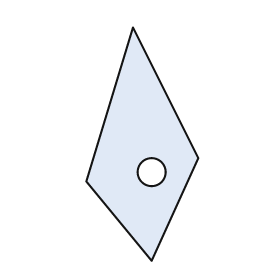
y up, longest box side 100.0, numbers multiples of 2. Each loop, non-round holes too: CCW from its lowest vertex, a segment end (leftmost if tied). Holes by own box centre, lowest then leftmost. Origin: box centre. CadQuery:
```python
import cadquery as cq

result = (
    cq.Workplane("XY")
    .moveTo(4.0, -50.0)
    .lineTo(24.0, -6.0)
    .lineTo(-4.0, 50.0)
    .lineTo(-24.0, -16.0)
    .close()
    .moveTo(4.0, -12.0)
    .circle(6.0)
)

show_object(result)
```